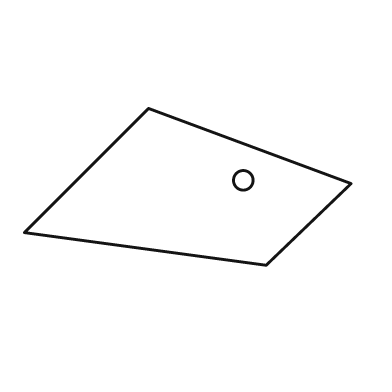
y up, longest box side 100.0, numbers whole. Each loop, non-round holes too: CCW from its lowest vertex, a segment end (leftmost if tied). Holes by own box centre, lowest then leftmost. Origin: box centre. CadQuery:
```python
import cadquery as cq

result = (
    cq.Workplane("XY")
    .moveTo(24.0, -24.0)
    .lineTo(50.0, 1.0)
    .lineTo(-12.0, 24.0)
    .lineTo(-50.0, -14.0)
    .close()
    .moveTo(17.0, 2.0)
    .circle(3.0)
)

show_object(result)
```